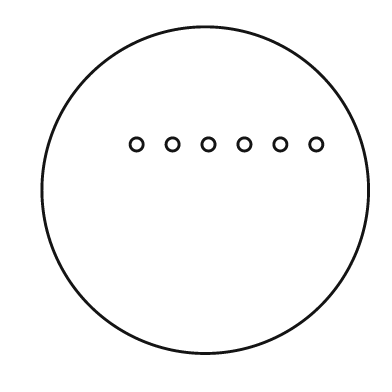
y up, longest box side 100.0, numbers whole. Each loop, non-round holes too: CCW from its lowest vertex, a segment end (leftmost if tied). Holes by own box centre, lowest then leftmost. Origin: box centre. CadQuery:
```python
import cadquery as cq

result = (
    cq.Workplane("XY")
    .moveTo(0.0, 0.0)
    .circle(50.0)
    .moveTo(-21.0, 14.0)
    .circle(2.0)
    .moveTo(-10.0, 14.0)
    .circle(2.0)
    .moveTo(1.0, 14.0)
    .circle(2.0)
    .moveTo(12.0, 14.0)
    .circle(2.0)
    .moveTo(23.0, 14.0)
    .circle(2.0)
    .moveTo(34.0, 14.0)
    .circle(2.0)
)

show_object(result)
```